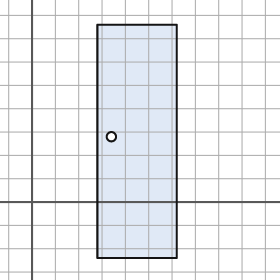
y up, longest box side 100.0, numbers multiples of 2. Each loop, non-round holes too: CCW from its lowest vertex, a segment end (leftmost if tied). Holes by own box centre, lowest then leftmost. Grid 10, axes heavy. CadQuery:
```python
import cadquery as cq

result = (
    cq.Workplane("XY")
    .moveTo(28.0, -24.0)
    .lineTo(62.0, -24.0)
    .lineTo(62.0, 76.0)
    .lineTo(28.0, 76.0)
    .close()
    .moveTo(34.0, 28.0)
    .circle(2.0)
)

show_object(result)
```